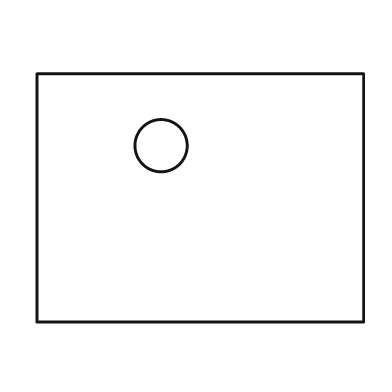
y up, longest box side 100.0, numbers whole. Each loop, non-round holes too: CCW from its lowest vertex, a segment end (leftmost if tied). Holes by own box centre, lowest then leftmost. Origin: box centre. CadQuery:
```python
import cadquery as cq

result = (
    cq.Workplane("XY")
    .moveTo(-50.0, -38.0)
    .lineTo(50.0, -38.0)
    .lineTo(50.0, 38.0)
    .lineTo(-50.0, 38.0)
    .close()
    .moveTo(-12.0, 16.0)
    .circle(8.0)
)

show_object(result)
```